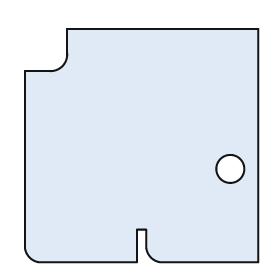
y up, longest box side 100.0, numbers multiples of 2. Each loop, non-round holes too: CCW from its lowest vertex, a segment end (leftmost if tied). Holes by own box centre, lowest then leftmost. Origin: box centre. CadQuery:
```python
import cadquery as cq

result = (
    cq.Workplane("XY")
    .moveTo(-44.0, -50.0)
    .lineTo(-2.0, -50.0)
    .lineTo(-2.0, -36.0)
    .lineTo(2.0, -36.0)
    .lineTo(2.0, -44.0)
    .threePointArc((4.0, -48.0), (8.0, -50.0))
    .lineTo(50.0, -50.0)
    .lineTo(50.0, 50.0)
    .lineTo(-32.0, 50.0)
    .lineTo(-32.0, 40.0)
    .threePointArc((-34.0, 34.0), (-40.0, 32.0))
    .lineTo(-50.0, 32.0)
    .lineTo(-50.0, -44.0)
    .threePointArc((-48.0, -48.0), (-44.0, -50.0))
    .close()
    .moveTo(38.0, -10.0)
    .circle(6.0)
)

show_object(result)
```